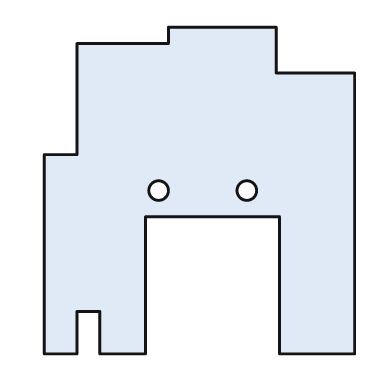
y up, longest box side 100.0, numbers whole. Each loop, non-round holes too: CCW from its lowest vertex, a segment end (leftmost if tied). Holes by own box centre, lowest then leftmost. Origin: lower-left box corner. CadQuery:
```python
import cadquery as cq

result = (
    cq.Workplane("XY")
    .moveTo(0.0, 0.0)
    .lineTo(10.0, 0.0)
    .lineTo(10.0, 13.0)
    .lineTo(17.0, 13.0)
    .lineTo(17.0, 0.0)
    .lineTo(31.0, 0.0)
    .lineTo(31.0, 42.0)
    .lineTo(72.0, 42.0)
    .lineTo(72.0, 0.0)
    .lineTo(95.0, 0.0)
    .lineTo(95.0, 86.0)
    .lineTo(71.0, 86.0)
    .lineTo(71.0, 100.0)
    .lineTo(38.0, 100.0)
    .lineTo(38.0, 95.0)
    .lineTo(10.0, 95.0)
    .lineTo(10.0, 61.0)
    .lineTo(0.0, 61.0)
    .close()
    .moveTo(35.0, 50.0)
    .circle(3.0)
    .moveTo(62.0, 50.0)
    .circle(3.0)
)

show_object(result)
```